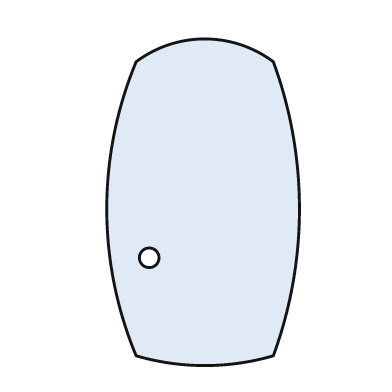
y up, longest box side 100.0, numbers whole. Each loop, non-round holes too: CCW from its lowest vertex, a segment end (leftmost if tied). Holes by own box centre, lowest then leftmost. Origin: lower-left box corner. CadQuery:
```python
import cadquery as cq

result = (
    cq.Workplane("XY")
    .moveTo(9.0, 3.0)
    .threePointArc((30.0, 0.0), (51.0, 3.0))
    .threePointArc((59.0, 48.0), (51.0, 93.0))
    .threePointArc((30.0, 100.0), (9.0, 93.0))
    .threePointArc((0.0, 48.0), (9.0, 3.0))
    .close()
    .moveTo(13.0, 33.0)
    .circle(3.0)
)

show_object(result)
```